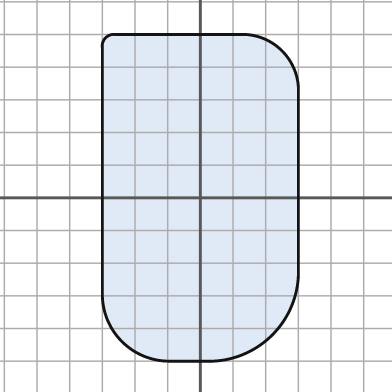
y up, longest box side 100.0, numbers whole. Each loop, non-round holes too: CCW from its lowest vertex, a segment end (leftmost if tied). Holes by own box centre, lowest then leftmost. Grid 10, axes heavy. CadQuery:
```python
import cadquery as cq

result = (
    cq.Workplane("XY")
    .moveTo(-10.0, -50.0)
    .lineTo(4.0, -50.0)
    .threePointArc((22.0, -42.0), (30.0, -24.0))
    .lineTo(30.0, 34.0)
    .threePointArc((25.0, 45.0), (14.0, 50.0))
    .lineTo(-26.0, 50.0)
    .threePointArc((-29.0, 49.0), (-30.0, 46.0))
    .lineTo(-30.0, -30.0)
    .threePointArc((-24.0, -44.0), (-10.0, -50.0))
    .close()
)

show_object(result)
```